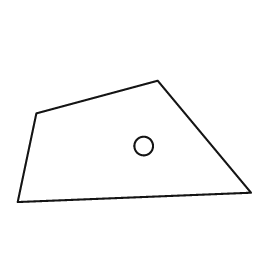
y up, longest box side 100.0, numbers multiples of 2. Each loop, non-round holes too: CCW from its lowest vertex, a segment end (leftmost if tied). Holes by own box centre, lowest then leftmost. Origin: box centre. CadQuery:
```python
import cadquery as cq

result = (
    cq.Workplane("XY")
    .moveTo(-50.0, -26.0)
    .lineTo(50.0, -22.0)
    .lineTo(10.0, 26.0)
    .lineTo(-42.0, 12.0)
    .close()
    .moveTo(4.0, -2.0)
    .circle(4.0)
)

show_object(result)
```